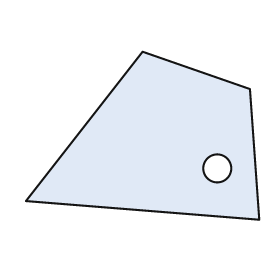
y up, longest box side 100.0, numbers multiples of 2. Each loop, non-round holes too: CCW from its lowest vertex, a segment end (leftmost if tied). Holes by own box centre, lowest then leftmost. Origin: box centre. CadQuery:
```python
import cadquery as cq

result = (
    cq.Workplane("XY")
    .moveTo(50.0, -36.0)
    .lineTo(46.0, 20.0)
    .lineTo(0.0, 36.0)
    .lineTo(-50.0, -28.0)
    .close()
    .moveTo(32.0, -14.0)
    .circle(6.0)
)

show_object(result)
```